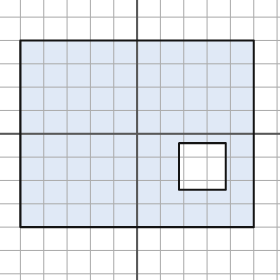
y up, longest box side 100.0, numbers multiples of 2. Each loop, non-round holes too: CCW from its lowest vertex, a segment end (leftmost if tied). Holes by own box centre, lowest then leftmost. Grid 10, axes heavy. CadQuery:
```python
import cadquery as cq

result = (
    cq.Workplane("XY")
    .moveTo(-50.0, -40.0)
    .lineTo(50.0, -40.0)
    .lineTo(50.0, 40.0)
    .lineTo(-50.0, 40.0)
    .close()
    .moveTo(18.0, -24.0)
    .lineTo(38.0, -24.0)
    .lineTo(38.0, -4.0)
    .lineTo(18.0, -4.0)
    .close()
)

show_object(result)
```